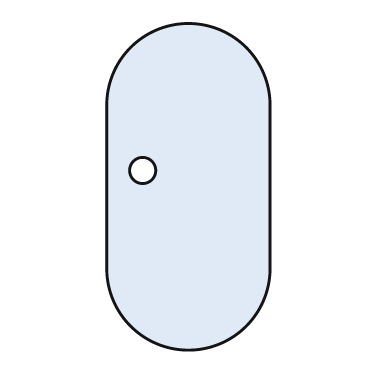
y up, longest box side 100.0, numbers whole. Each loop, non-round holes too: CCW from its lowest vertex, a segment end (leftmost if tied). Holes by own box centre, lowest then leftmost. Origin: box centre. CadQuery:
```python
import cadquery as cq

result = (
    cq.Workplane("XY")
    .moveTo(-25.0, -25.0)
    .threePointArc((0.0, -50.0), (25.0, -25.0))
    .lineTo(25.0, 25.0)
    .threePointArc((0.0, 50.0), (-25.0, 25.0))
    .close()
    .moveTo(-14.0, 5.0)
    .circle(4.0)
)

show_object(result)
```